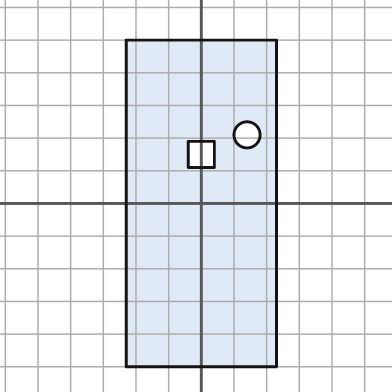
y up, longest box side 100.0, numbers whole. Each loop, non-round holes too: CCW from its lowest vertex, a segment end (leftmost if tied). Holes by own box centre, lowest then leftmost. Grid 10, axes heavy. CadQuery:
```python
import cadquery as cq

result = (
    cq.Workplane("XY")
    .moveTo(-23.0, -50.0)
    .lineTo(23.0, -50.0)
    .lineTo(23.0, 50.0)
    .lineTo(-23.0, 50.0)
    .close()
    .moveTo(-4.0, 11.0)
    .lineTo(4.0, 11.0)
    .lineTo(4.0, 19.0)
    .lineTo(-4.0, 19.0)
    .close()
    .moveTo(14.0, 21.0)
    .circle(4.0)
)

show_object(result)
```